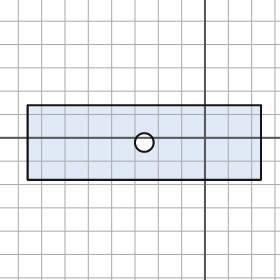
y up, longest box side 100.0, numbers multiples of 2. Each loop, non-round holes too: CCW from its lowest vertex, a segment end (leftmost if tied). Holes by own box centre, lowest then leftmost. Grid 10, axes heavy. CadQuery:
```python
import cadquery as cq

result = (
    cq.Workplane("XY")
    .moveTo(-76.0, -18.0)
    .lineTo(24.0, -18.0)
    .lineTo(24.0, 14.0)
    .lineTo(-76.0, 14.0)
    .close()
    .moveTo(-26.0, -2.0)
    .circle(4.0)
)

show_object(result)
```